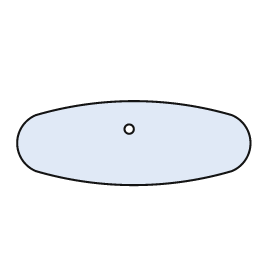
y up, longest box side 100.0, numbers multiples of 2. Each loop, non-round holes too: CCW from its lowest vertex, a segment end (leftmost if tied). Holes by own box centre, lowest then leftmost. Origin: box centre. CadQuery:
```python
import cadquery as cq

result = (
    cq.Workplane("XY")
    .moveTo(-42.0, -12.0)
    .threePointArc((0.0, -18.0), (42.0, -12.0))
    .threePointArc((50.0, 0.0), (42.0, 12.0))
    .threePointArc((0.0, 18.0), (-42.0, 12.0))
    .threePointArc((-50.0, 0.0), (-42.0, -12.0))
    .close()
    .moveTo(-2.0, 6.0)
    .circle(2.0)
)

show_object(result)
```